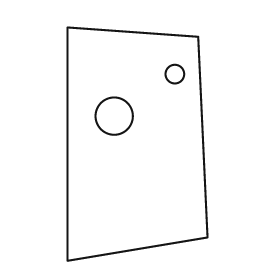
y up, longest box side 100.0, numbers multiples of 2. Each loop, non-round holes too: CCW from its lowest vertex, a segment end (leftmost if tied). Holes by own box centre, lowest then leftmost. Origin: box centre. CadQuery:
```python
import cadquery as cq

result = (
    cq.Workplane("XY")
    .moveTo(-30.0, -50.0)
    .lineTo(30.0, -40.0)
    .lineTo(26.0, 46.0)
    .lineTo(-30.0, 50.0)
    .close()
    .moveTo(-10.0, 12.0)
    .circle(8.0)
    .moveTo(16.0, 30.0)
    .circle(4.0)
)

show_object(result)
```